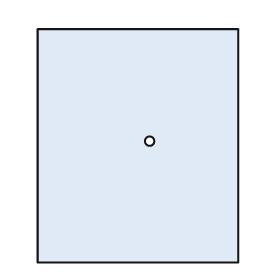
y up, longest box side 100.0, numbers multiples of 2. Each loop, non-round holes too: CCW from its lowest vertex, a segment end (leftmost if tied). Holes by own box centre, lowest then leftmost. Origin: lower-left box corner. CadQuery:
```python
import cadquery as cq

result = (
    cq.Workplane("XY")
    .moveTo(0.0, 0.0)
    .lineTo(86.0, 0.0)
    .lineTo(86.0, 100.0)
    .lineTo(0.0, 100.0)
    .close()
    .moveTo(48.0, 52.0)
    .circle(2.0)
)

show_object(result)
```